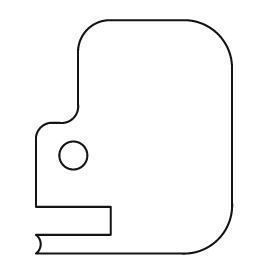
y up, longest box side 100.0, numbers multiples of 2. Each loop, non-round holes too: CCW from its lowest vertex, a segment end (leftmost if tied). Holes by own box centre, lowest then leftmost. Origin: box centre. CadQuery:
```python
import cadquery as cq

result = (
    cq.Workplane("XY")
    .moveTo(-42.0, -50.0)
    .lineTo(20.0, -50.0)
    .threePointArc((36.0, -44.0), (42.0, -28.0))
    .lineTo(42.0, 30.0)
    .threePointArc((36.0, 44.0), (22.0, 50.0))
    .lineTo(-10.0, 50.0)
    .threePointArc((-20.0, 46.0), (-24.0, 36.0))
    .lineTo(-24.0, 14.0)
    .threePointArc((-26.0, 8.0), (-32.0, 6.0))
    .lineTo(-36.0, 6.0)
    .threePointArc((-40.0, 4.0), (-42.0, 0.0))
    .lineTo(-42.0, -30.0)
    .lineTo(-10.0, -30.0)
    .lineTo(-10.0, -42.0)
    .lineTo(-42.0, -42.0)
    .threePointArc((-40.0, -46.0), (-42.0, -50.0))
    .close()
    .moveTo(-26.0, -8.0)
    .circle(6.0)
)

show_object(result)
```